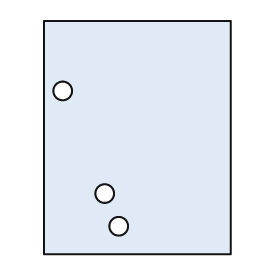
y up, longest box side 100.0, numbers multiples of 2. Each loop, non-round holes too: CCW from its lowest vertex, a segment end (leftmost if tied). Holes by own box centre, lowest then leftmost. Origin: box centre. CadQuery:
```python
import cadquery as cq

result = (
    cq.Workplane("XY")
    .moveTo(-40.0, -50.0)
    .lineTo(40.0, -50.0)
    .lineTo(40.0, 50.0)
    .lineTo(-40.0, 50.0)
    .close()
    .moveTo(-8.0, -38.0)
    .circle(4.0)
    .moveTo(-14.0, -24.0)
    .circle(4.0)
    .moveTo(-32.0, 20.0)
    .circle(4.0)
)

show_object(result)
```